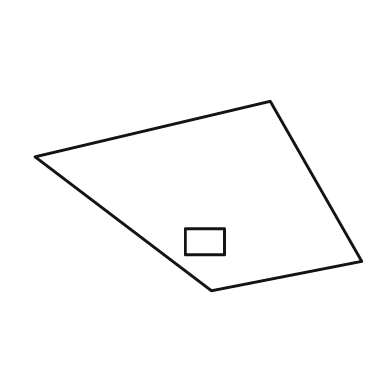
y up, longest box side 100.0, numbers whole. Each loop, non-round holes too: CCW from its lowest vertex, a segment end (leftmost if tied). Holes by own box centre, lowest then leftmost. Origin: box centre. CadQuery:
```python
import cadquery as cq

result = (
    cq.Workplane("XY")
    .moveTo(4.0, -29.0)
    .lineTo(50.0, -20.0)
    .lineTo(22.0, 29.0)
    .lineTo(-50.0, 12.0)
    .close()
    .moveTo(-4.0, -18.0)
    .lineTo(8.0, -18.0)
    .lineTo(8.0, -10.0)
    .lineTo(-4.0, -10.0)
    .close()
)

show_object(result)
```